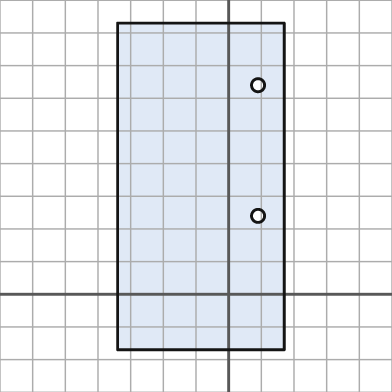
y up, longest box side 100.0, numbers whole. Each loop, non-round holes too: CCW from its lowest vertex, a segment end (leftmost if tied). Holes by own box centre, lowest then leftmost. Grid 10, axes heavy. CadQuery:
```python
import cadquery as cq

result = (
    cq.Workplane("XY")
    .moveTo(-34.0, -17.0)
    .lineTo(17.0, -17.0)
    .lineTo(17.0, 83.0)
    .lineTo(-34.0, 83.0)
    .close()
    .moveTo(9.0, 24.0)
    .circle(2.0)
    .moveTo(9.0, 64.0)
    .circle(2.0)
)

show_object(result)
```